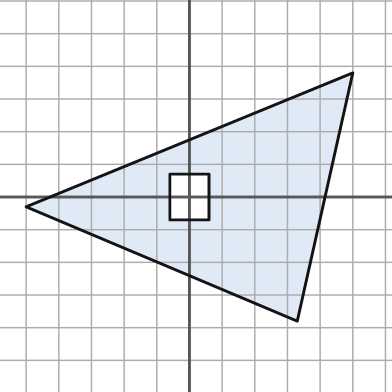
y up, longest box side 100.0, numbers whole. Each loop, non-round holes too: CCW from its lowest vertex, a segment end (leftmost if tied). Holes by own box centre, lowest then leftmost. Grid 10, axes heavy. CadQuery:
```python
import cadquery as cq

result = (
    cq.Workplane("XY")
    .moveTo(33.0, -38.0)
    .lineTo(50.0, 38.0)
    .lineTo(-50.0, -3.0)
    .close()
    .moveTo(-6.0, -7.0)
    .lineTo(6.0, -7.0)
    .lineTo(6.0, 7.0)
    .lineTo(-6.0, 7.0)
    .close()
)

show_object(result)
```